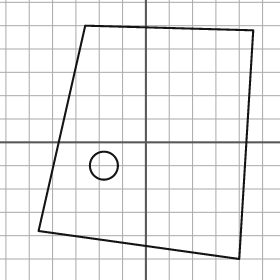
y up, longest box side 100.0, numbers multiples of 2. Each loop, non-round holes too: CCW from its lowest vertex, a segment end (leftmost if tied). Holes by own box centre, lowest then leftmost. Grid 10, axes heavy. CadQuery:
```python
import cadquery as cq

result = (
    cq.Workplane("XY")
    .moveTo(40.0, -50.0)
    .lineTo(46.0, 48.0)
    .lineTo(-26.0, 50.0)
    .lineTo(-46.0, -38.0)
    .close()
    .moveTo(-18.0, -10.0)
    .circle(6.0)
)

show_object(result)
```